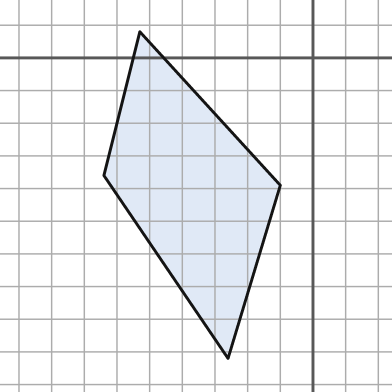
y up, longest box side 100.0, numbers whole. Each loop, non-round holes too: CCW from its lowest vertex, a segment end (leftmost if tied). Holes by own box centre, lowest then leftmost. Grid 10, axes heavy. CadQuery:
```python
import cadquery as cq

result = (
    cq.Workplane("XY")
    .moveTo(-26.0, -92.0)
    .lineTo(-10.0, -39.0)
    .lineTo(-53.0, 8.0)
    .lineTo(-64.0, -36.0)
    .close()
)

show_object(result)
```